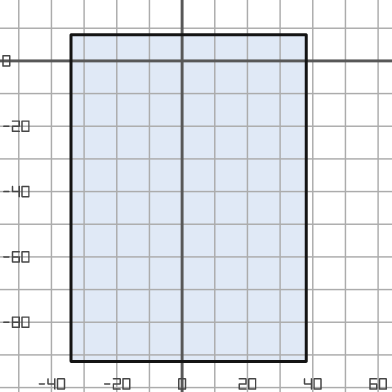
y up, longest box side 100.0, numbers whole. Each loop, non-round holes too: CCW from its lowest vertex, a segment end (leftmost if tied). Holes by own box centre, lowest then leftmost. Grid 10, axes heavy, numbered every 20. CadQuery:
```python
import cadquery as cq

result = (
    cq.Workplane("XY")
    .moveTo(-34.0, -92.0)
    .lineTo(38.0, -92.0)
    .lineTo(38.0, 8.0)
    .lineTo(-34.0, 8.0)
    .close()
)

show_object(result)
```